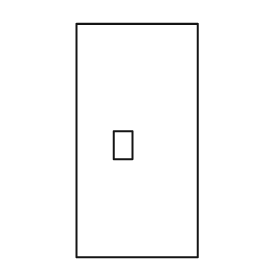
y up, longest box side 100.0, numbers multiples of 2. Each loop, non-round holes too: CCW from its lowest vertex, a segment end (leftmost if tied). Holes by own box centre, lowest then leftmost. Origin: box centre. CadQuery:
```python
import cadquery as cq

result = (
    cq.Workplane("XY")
    .moveTo(-26.0, -50.0)
    .lineTo(26.0, -50.0)
    .lineTo(26.0, 50.0)
    .lineTo(-26.0, 50.0)
    .close()
    .moveTo(-10.0, -8.0)
    .lineTo(-2.0, -8.0)
    .lineTo(-2.0, 4.0)
    .lineTo(-10.0, 4.0)
    .close()
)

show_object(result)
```